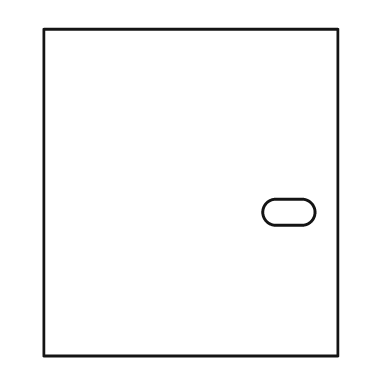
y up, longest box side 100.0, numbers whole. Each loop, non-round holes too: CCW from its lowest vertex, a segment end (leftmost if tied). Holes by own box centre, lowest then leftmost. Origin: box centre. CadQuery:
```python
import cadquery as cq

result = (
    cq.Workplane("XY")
    .moveTo(-45.0, -50.0)
    .lineTo(45.0, -50.0)
    .lineTo(45.0, 50.0)
    .lineTo(-45.0, 50.0)
    .close()
    .moveTo(26.0, -10.0)
    .lineTo(34.0, -10.0)
    .threePointArc((38.0, -6.0), (34.0, -2.0))
    .lineTo(26.0, -2.0)
    .threePointArc((22.0, -6.0), (26.0, -10.0))
    .close()
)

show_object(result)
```